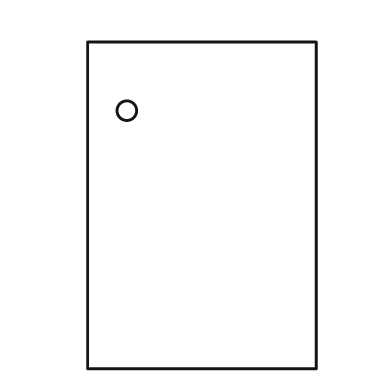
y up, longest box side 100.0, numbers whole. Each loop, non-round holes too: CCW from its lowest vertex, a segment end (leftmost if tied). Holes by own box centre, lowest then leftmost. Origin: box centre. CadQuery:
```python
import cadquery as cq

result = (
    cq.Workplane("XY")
    .moveTo(-35.0, -50.0)
    .lineTo(35.0, -50.0)
    .lineTo(35.0, 50.0)
    .lineTo(-35.0, 50.0)
    .close()
    .moveTo(-23.0, 29.0)
    .circle(3.0)
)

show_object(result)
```